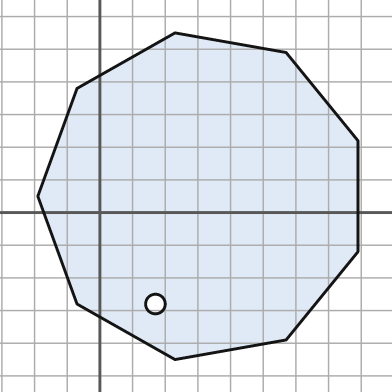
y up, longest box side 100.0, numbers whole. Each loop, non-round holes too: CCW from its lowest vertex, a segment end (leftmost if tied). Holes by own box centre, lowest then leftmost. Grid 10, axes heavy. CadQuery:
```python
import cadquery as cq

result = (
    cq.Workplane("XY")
    .moveTo(23.0, -45.0)
    .lineTo(57.0, -39.0)
    .lineTo(79.0, -12.0)
    .lineTo(79.0, 22.0)
    .lineTo(57.0, 49.0)
    .lineTo(23.0, 55.0)
    .lineTo(-7.0, 38.0)
    .lineTo(-19.0, 5.0)
    .lineTo(-7.0, -28.0)
    .close()
    .moveTo(17.0, -28.0)
    .circle(3.0)
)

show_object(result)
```